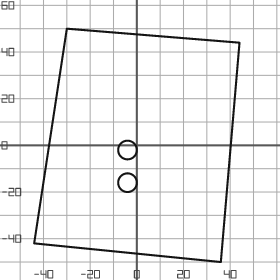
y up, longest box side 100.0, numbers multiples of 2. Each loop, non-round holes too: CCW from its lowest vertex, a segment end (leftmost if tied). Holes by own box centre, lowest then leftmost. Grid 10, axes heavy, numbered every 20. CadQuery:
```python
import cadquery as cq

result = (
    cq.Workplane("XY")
    .moveTo(36.0, -50.0)
    .lineTo(44.0, 44.0)
    .lineTo(-30.0, 50.0)
    .lineTo(-44.0, -42.0)
    .close()
    .moveTo(-4.0, -16.0)
    .circle(4.0)
    .moveTo(-4.0, -2.0)
    .circle(4.0)
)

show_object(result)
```